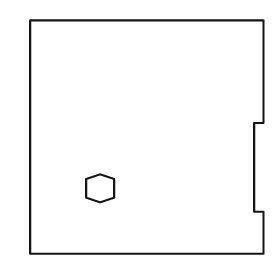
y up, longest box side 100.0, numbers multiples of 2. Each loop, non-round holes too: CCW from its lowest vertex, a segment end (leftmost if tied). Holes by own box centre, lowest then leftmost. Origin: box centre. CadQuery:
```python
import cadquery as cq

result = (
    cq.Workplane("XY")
    .moveTo(-50.0, -50.0)
    .lineTo(50.0, -50.0)
    .lineTo(50.0, -32.0)
    .lineTo(46.0, -32.0)
    .lineTo(46.0, 6.0)
    .lineTo(50.0, 6.0)
    .lineTo(50.0, 50.0)
    .lineTo(-50.0, 50.0)
    .close()
    .moveTo(-20.0, -28.0)
    .lineTo(-14.0, -26.0)
    .lineTo(-14.0, -18.0)
    .lineTo(-20.0, -16.0)
    .lineTo(-26.0, -18.0)
    .lineTo(-26.0, -26.0)
    .close()
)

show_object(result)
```